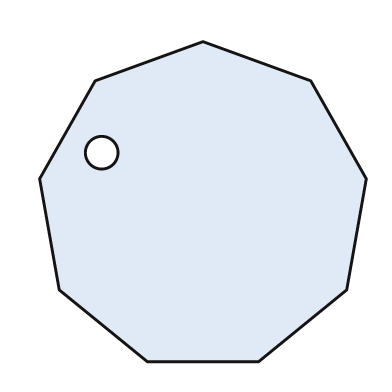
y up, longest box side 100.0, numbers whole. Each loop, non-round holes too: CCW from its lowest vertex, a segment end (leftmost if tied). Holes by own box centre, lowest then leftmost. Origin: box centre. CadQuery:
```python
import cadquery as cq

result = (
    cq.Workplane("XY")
    .moveTo(-17.0, -49.0)
    .lineTo(17.0, -49.0)
    .lineTo(44.0, -27.0)
    .lineTo(50.0, 7.0)
    .lineTo(33.0, 37.0)
    .lineTo(0.0, 49.0)
    .lineTo(-33.0, 37.0)
    .lineTo(-50.0, 7.0)
    .lineTo(-44.0, -27.0)
    .close()
    .moveTo(-31.0, 15.0)
    .circle(5.0)
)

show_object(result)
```